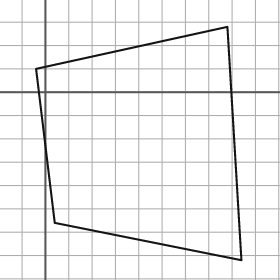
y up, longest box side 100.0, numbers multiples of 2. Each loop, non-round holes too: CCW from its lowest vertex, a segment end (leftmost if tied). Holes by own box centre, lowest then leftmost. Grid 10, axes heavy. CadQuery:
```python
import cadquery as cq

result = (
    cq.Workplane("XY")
    .moveTo(84.0, -72.0)
    .lineTo(78.0, 28.0)
    .lineTo(-4.0, 10.0)
    .lineTo(4.0, -56.0)
    .close()
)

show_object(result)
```